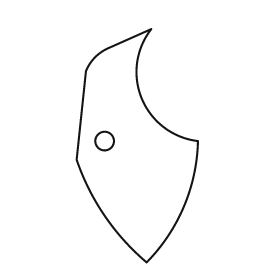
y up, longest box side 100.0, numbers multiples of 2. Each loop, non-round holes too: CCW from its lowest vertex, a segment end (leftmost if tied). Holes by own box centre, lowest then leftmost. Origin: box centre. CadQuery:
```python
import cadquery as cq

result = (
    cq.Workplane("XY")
    .moveTo(4.0, -50.0)
    .threePointArc((20.0, -26.0), (26.0, 2.0))
    .threePointArc((2.0, 20.0), (6.0, 50.0))
    .lineTo(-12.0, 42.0)
    .threePointArc((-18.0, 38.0), (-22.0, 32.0))
    .lineTo(-26.0, -6.0)
    .threePointArc((-14.0, -30.0), (4.0, -50.0))
    .close()
    .moveTo(-14.0, 2.0)
    .circle(4.0)
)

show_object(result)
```